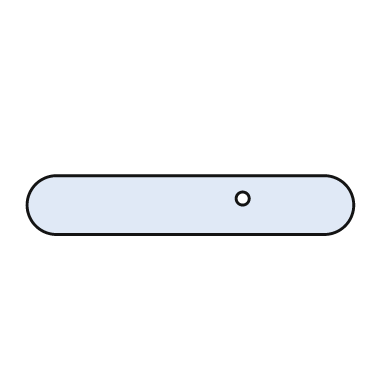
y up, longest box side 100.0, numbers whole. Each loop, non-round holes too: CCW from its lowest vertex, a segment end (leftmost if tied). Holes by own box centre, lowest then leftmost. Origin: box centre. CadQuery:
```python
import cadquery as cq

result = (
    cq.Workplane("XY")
    .moveTo(-41.0, -9.0)
    .lineTo(41.0, -9.0)
    .threePointArc((50.0, 0.0), (41.0, 9.0))
    .lineTo(-41.0, 9.0)
    .threePointArc((-50.0, 0.0), (-41.0, -9.0))
    .close()
    .moveTo(16.0, 2.0)
    .circle(2.0)
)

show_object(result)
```